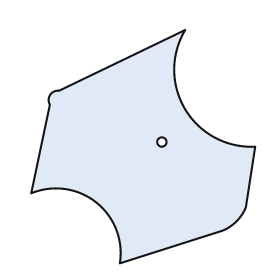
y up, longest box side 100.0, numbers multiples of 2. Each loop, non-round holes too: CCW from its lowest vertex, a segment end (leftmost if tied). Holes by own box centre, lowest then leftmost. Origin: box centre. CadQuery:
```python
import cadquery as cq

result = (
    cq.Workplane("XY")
    .moveTo(-10.0, -50.0)
    .lineTo(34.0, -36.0)
    .threePointArc((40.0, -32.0), (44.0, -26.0))
    .lineTo(48.0, 0.0)
    .threePointArc((18.0, 16.0), (18.0, 50.0))
    .lineTo(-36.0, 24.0)
    .threePointArc((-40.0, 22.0), (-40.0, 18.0))
    .lineTo(-48.0, -20.0)
    .threePointArc((-20.0, -24.0), (-10.0, -50.0))
    .close()
    .moveTo(8.0, 2.0)
    .circle(2.0)
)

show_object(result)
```